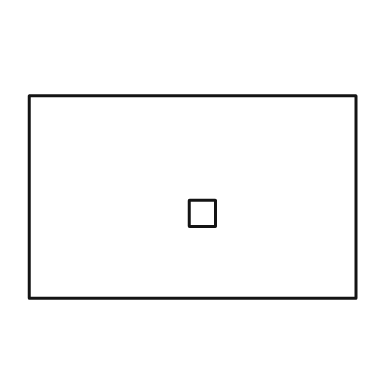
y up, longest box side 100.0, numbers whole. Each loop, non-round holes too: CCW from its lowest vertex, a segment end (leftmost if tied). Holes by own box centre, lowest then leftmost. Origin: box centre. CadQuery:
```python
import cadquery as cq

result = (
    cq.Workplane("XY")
    .moveTo(-50.0, -31.0)
    .lineTo(50.0, -31.0)
    .lineTo(50.0, 31.0)
    .lineTo(-50.0, 31.0)
    .close()
    .moveTo(-1.0, -9.0)
    .lineTo(7.0, -9.0)
    .lineTo(7.0, -1.0)
    .lineTo(-1.0, -1.0)
    .close()
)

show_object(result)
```